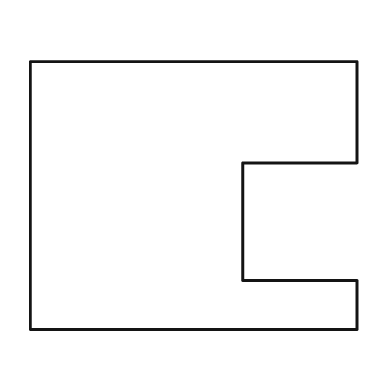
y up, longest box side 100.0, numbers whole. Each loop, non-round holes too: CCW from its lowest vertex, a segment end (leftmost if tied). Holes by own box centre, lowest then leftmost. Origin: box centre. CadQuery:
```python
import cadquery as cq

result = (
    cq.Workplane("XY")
    .moveTo(-50.0, -41.0)
    .lineTo(50.0, -41.0)
    .lineTo(50.0, -26.0)
    .lineTo(15.0, -26.0)
    .lineTo(15.0, 10.0)
    .lineTo(50.0, 10.0)
    .lineTo(50.0, 41.0)
    .lineTo(-50.0, 41.0)
    .close()
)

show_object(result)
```